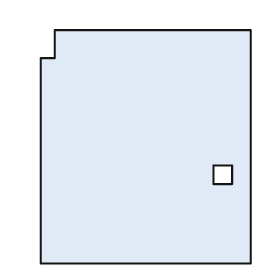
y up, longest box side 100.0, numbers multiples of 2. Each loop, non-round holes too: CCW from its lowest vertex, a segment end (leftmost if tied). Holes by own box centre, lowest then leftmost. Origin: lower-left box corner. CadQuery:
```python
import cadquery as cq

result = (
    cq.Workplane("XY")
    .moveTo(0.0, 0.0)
    .lineTo(90.0, 0.0)
    .lineTo(90.0, 100.0)
    .lineTo(6.0, 100.0)
    .lineTo(6.0, 88.0)
    .lineTo(0.0, 88.0)
    .close()
    .moveTo(74.0, 34.0)
    .lineTo(82.0, 34.0)
    .lineTo(82.0, 42.0)
    .lineTo(74.0, 42.0)
    .close()
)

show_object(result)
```